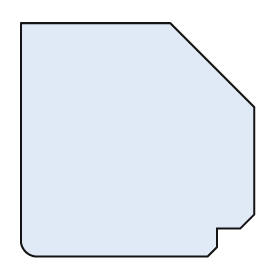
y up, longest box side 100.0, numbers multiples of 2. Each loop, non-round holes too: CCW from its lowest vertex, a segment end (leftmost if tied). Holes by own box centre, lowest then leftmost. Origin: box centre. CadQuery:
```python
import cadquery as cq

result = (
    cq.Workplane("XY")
    .moveTo(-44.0, -50.0)
    .lineTo(30.0, -50.0)
    .lineTo(34.0, -46.0)
    .lineTo(34.0, -38.0)
    .lineTo(44.0, -38.0)
    .lineTo(50.0, -32.0)
    .lineTo(50.0, 14.0)
    .lineTo(14.0, 50.0)
    .lineTo(-50.0, 50.0)
    .lineTo(-50.0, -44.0)
    .threePointArc((-48.0, -48.0), (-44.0, -50.0))
    .close()
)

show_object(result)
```